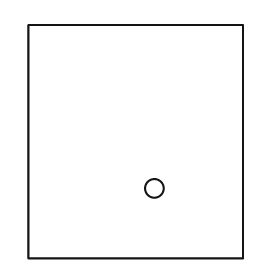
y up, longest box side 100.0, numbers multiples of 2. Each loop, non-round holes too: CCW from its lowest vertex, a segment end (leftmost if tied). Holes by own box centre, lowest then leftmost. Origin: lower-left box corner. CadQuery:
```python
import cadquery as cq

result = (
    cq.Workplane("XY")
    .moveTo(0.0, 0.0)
    .lineTo(92.0, 0.0)
    .lineTo(92.0, 100.0)
    .lineTo(0.0, 100.0)
    .close()
    .moveTo(54.0, 30.0)
    .circle(4.0)
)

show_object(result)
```